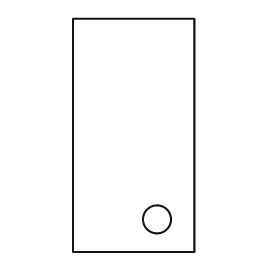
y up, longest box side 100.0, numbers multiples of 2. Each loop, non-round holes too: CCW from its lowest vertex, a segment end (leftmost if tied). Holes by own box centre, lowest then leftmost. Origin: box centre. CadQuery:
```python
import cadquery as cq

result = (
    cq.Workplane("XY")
    .moveTo(-26.0, -50.0)
    .lineTo(26.0, -50.0)
    .lineTo(26.0, 50.0)
    .lineTo(-26.0, 50.0)
    .close()
    .moveTo(10.0, -36.0)
    .circle(6.0)
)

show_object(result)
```